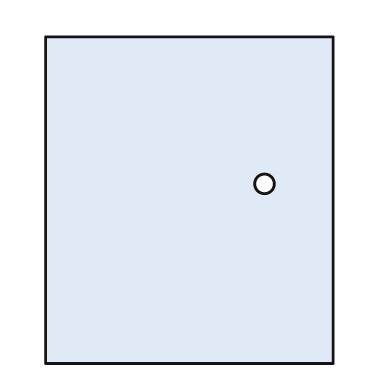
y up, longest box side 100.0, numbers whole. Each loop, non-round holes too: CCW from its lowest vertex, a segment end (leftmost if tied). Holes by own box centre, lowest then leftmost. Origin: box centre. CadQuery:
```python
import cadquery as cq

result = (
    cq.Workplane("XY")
    .moveTo(-44.0, -50.0)
    .lineTo(44.0, -50.0)
    .lineTo(44.0, 50.0)
    .lineTo(-44.0, 50.0)
    .close()
    .moveTo(23.0, 5.0)
    .circle(3.0)
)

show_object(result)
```